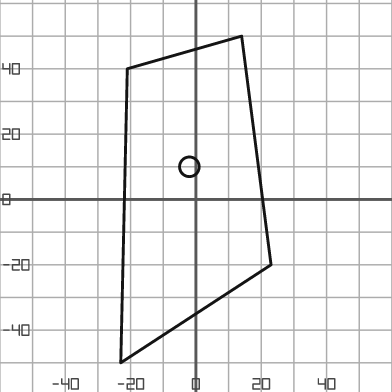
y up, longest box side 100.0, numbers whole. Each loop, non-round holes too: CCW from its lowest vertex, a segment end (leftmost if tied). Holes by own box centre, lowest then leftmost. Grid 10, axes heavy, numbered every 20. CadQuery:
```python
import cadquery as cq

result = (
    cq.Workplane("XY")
    .moveTo(-23.0, -50.0)
    .lineTo(23.0, -20.0)
    .lineTo(14.0, 50.0)
    .lineTo(-21.0, 40.0)
    .close()
    .moveTo(-2.0, 10.0)
    .circle(3.0)
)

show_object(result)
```